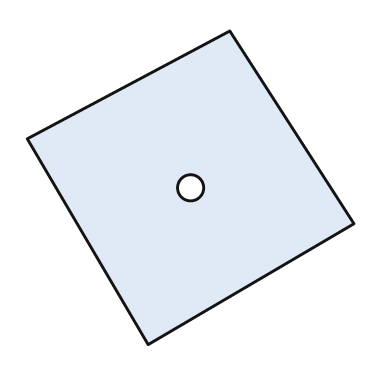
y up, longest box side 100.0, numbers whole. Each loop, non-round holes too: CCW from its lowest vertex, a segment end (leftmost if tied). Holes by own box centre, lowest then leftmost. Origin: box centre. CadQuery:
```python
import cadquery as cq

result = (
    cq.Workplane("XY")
    .moveTo(-13.0, -48.0)
    .lineTo(50.0, -11.0)
    .lineTo(12.0, 48.0)
    .lineTo(-50.0, 15.0)
    .close()
    .moveTo(0.0, 0.0)
    .circle(4.0)
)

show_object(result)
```